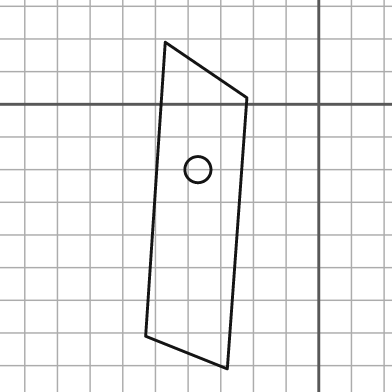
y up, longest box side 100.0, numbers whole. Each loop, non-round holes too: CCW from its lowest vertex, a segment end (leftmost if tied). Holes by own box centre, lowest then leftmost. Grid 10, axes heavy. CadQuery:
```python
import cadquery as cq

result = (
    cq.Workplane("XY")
    .moveTo(-28.0, -81.0)
    .lineTo(-22.0, 2.0)
    .lineTo(-47.0, 19.0)
    .lineTo(-53.0, -71.0)
    .close()
    .moveTo(-37.0, -20.0)
    .circle(4.0)
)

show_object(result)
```